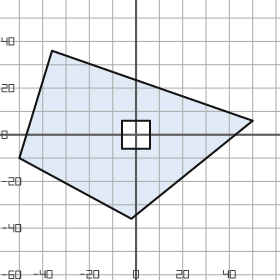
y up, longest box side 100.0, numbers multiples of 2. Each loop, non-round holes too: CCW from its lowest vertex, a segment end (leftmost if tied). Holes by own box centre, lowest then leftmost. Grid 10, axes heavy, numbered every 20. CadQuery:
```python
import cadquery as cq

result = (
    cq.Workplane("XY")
    .moveTo(-2.0, -36.0)
    .lineTo(50.0, 6.0)
    .lineTo(-36.0, 36.0)
    .lineTo(-50.0, -10.0)
    .close()
    .moveTo(-6.0, -6.0)
    .lineTo(6.0, -6.0)
    .lineTo(6.0, 6.0)
    .lineTo(-6.0, 6.0)
    .close()
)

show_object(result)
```